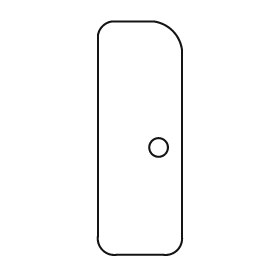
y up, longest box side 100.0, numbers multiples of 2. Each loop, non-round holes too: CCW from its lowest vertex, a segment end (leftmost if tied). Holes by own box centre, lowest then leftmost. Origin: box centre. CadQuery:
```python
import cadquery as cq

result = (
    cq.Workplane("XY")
    .moveTo(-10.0, -50.0)
    .lineTo(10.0, -50.0)
    .threePointArc((16.0, -48.0), (18.0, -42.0))
    .lineTo(18.0, 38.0)
    .threePointArc((14.0, 46.0), (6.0, 50.0))
    .lineTo(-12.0, 50.0)
    .threePointArc((-16.0, 48.0), (-18.0, 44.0))
    .lineTo(-18.0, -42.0)
    .threePointArc((-16.0, -48.0), (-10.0, -50.0))
    .close()
    .moveTo(8.0, -4.0)
    .circle(4.0)
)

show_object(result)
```